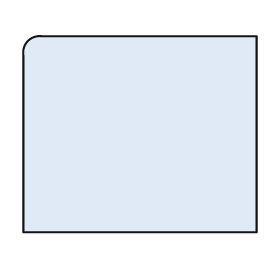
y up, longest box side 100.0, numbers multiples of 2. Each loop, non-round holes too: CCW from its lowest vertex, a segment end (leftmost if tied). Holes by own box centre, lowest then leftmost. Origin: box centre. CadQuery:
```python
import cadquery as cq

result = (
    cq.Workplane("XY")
    .moveTo(-50.0, -42.0)
    .lineTo(50.0, -42.0)
    .lineTo(50.0, 42.0)
    .lineTo(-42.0, 42.0)
    .threePointArc((-48.0, 40.0), (-50.0, 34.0))
    .close()
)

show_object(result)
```